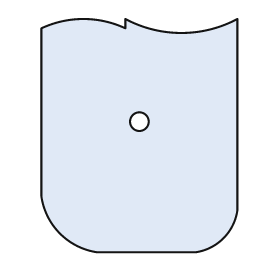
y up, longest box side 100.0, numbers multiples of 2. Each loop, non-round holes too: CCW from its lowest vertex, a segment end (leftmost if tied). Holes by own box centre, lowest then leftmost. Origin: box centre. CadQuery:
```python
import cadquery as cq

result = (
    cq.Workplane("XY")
    .moveTo(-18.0, -50.0)
    .lineTo(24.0, -50.0)
    .threePointArc((36.0, -44.0), (42.0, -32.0))
    .lineTo(42.0, 50.0)
    .threePointArc((18.0, 44.0), (-6.0, 50.0))
    .lineTo(-6.0, 46.0)
    .threePointArc((-24.0, 50.0), (-42.0, 46.0))
    .lineTo(-42.0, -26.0)
    .threePointArc((-34.0, -42.0), (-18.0, -50.0))
    .close()
    .moveTo(0.0, 6.0)
    .circle(4.0)
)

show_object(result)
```